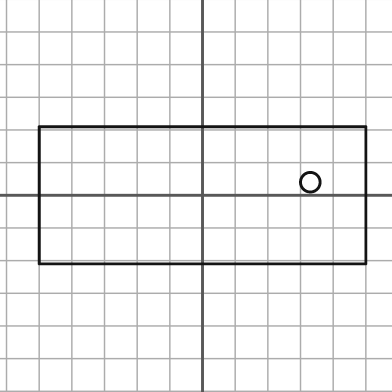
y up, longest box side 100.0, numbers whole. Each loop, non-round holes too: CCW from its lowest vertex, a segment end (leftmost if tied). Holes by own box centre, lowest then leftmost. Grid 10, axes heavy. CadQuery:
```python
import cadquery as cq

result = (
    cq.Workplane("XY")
    .moveTo(-50.0, -21.0)
    .lineTo(50.0, -21.0)
    .lineTo(50.0, 21.0)
    .lineTo(-50.0, 21.0)
    .close()
    .moveTo(33.0, 4.0)
    .circle(3.0)
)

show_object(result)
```